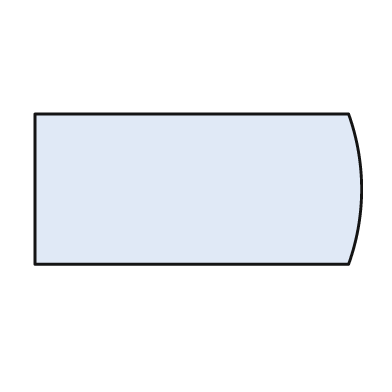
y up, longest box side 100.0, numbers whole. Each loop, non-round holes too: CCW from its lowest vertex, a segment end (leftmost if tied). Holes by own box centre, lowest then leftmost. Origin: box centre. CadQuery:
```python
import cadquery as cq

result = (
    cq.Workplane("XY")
    .moveTo(-50.0, -23.0)
    .lineTo(46.0, -23.0)
    .threePointArc((50.0, 0.0), (46.0, 23.0))
    .lineTo(-50.0, 23.0)
    .close()
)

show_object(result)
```